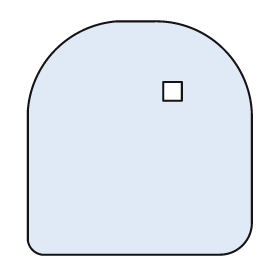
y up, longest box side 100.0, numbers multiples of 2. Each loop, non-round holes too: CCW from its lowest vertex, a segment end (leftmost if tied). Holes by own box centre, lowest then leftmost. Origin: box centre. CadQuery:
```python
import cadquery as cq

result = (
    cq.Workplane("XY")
    .moveTo(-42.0, -50.0)
    .lineTo(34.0, -50.0)
    .threePointArc((44.0, -46.0), (48.0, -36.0))
    .lineTo(48.0, 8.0)
    .threePointArc((36.0, 38.0), (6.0, 50.0))
    .lineTo(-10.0, 50.0)
    .threePointArc((-36.0, 38.0), (-48.0, 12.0))
    .lineTo(-48.0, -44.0)
    .threePointArc((-46.0, -48.0), (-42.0, -50.0))
    .close()
    .moveTo(10.0, 16.0)
    .lineTo(18.0, 16.0)
    .lineTo(18.0, 24.0)
    .lineTo(10.0, 24.0)
    .close()
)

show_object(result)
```